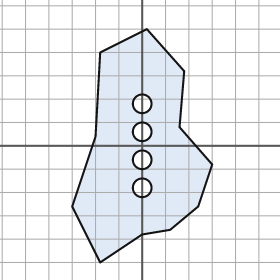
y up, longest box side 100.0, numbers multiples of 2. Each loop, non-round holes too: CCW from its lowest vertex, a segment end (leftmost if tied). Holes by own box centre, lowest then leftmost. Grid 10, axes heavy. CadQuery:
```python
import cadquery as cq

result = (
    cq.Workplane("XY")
    .moveTo(-18.0, -50.0)
    .lineTo(0.0, -38.0)
    .lineTo(12.0, -36.0)
    .lineTo(24.0, -26.0)
    .lineTo(30.0, -8.0)
    .lineTo(16.0, 8.0)
    .lineTo(18.0, 32.0)
    .lineTo(2.0, 50.0)
    .lineTo(-18.0, 40.0)
    .lineTo(-20.0, 4.0)
    .lineTo(-30.0, -26.0)
    .close()
    .moveTo(0.0, -18.0)
    .circle(4.0)
    .moveTo(0.0, -6.0)
    .circle(4.0)
    .moveTo(0.0, 6.0)
    .circle(4.0)
    .moveTo(0.0, 18.0)
    .circle(4.0)
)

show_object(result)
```